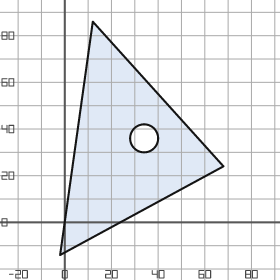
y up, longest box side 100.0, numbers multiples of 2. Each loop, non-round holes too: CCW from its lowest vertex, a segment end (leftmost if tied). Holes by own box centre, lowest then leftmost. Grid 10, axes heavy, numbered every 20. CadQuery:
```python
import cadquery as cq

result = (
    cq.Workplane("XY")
    .moveTo(-2.0, -14.0)
    .lineTo(68.0, 24.0)
    .lineTo(12.0, 86.0)
    .close()
    .moveTo(34.0, 36.0)
    .circle(6.0)
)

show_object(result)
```